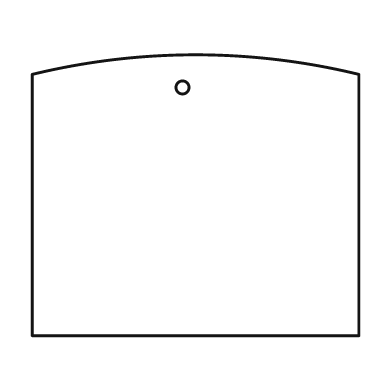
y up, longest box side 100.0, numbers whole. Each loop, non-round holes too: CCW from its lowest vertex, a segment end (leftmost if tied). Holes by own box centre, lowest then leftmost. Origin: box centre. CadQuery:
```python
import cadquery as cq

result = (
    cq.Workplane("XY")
    .moveTo(-50.0, -43.0)
    .lineTo(50.0, -43.0)
    .lineTo(50.0, 37.0)
    .threePointArc((0.0, 43.0), (-50.0, 37.0))
    .close()
    .moveTo(-4.0, 33.0)
    .circle(2.0)
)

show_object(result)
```